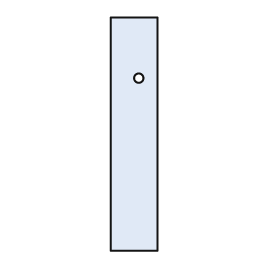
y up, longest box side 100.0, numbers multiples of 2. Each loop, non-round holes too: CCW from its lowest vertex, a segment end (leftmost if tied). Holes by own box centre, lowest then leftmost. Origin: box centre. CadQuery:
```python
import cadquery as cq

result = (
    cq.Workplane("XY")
    .moveTo(-10.0, -50.0)
    .lineTo(10.0, -50.0)
    .lineTo(10.0, 50.0)
    .lineTo(-10.0, 50.0)
    .close()
    .moveTo(2.0, 24.0)
    .circle(2.0)
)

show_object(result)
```